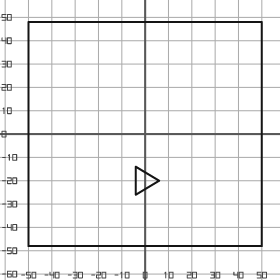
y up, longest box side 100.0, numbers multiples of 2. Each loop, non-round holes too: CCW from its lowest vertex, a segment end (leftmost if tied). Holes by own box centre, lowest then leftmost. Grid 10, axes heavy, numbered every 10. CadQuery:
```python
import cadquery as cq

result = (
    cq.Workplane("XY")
    .moveTo(-50.0, -48.0)
    .lineTo(50.0, -48.0)
    .lineTo(50.0, 48.0)
    .lineTo(-50.0, 48.0)
    .close()
    .moveTo(-4.0, -26.0)
    .lineTo(6.0, -20.0)
    .lineTo(-4.0, -14.0)
    .close()
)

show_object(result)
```